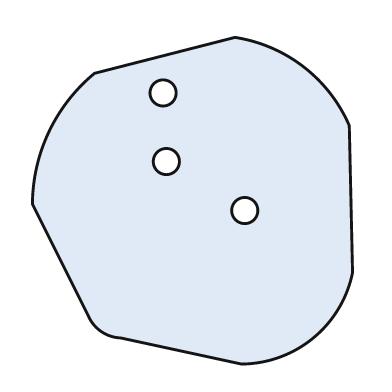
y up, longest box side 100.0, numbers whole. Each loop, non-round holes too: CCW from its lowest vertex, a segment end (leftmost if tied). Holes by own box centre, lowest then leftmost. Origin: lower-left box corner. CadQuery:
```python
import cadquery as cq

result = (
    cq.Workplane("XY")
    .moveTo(64.0, 0.0)
    .threePointArc((86.0, 8.0), (98.0, 28.0))
    .lineTo(97.0, 73.0)
    .threePointArc((83.0, 91.0), (62.0, 100.0))
    .lineTo(19.0, 89.0)
    .threePointArc((5.0, 71.0), (0.0, 49.0))
    .lineTo(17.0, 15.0)
    .threePointArc((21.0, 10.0), (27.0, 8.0))
    .close()
    .moveTo(65.0, 47.0)
    .circle(4.0)
    .moveTo(41.0, 62.0)
    .circle(4.0)
    .moveTo(40.0, 83.0)
    .circle(4.0)
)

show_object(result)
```